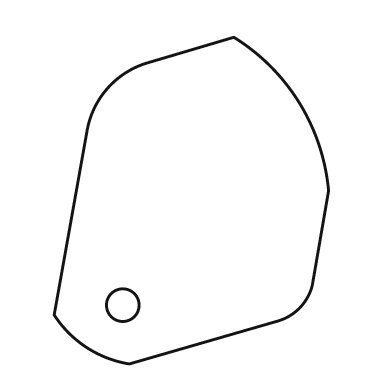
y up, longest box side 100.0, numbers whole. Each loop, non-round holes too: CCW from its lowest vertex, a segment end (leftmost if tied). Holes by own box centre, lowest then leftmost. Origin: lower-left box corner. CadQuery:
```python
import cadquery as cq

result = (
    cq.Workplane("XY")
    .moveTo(23.0, 0.0)
    .lineTo(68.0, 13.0)
    .threePointArc((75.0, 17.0), (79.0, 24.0))
    .lineTo(84.0, 53.0)
    .threePointArc((75.0, 80.0), (55.0, 100.0))
    .lineTo(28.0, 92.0)
    .threePointArc((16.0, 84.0), (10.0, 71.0))
    .lineTo(0.0, 15.0)
    .threePointArc((10.0, 5.0), (23.0, 0.0))
    .close()
    .moveTo(21.0, 18.0)
    .circle(5.0)
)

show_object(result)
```